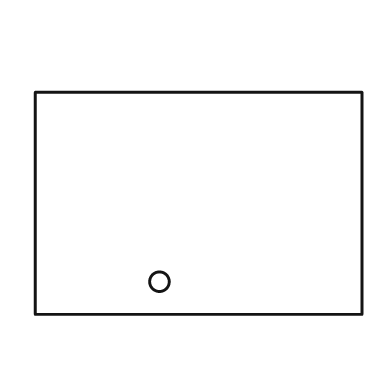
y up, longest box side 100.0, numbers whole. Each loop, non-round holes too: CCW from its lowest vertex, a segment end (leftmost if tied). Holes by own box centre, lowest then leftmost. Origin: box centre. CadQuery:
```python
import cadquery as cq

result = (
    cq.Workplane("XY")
    .moveTo(-50.0, -34.0)
    .lineTo(50.0, -34.0)
    .lineTo(50.0, 34.0)
    .lineTo(-50.0, 34.0)
    .close()
    .moveTo(-12.0, -24.0)
    .circle(3.0)
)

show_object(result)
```